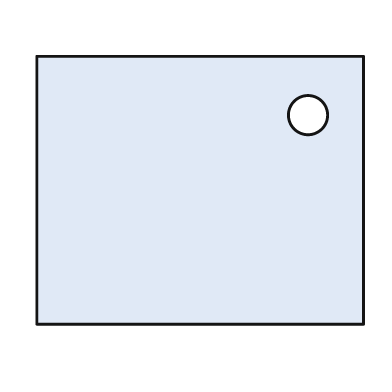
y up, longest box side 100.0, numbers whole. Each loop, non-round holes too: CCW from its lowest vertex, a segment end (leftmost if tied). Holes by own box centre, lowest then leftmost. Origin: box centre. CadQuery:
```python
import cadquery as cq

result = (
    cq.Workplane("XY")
    .moveTo(-50.0, -41.0)
    .lineTo(50.0, -41.0)
    .lineTo(50.0, 41.0)
    .lineTo(-50.0, 41.0)
    .close()
    .moveTo(33.0, 23.0)
    .circle(6.0)
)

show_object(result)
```